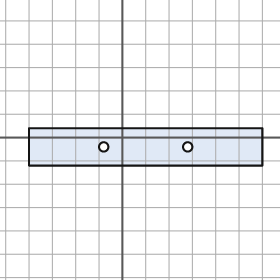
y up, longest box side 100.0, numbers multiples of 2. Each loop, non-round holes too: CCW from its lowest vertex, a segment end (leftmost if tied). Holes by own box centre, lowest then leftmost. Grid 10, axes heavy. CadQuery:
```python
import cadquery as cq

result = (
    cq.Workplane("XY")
    .moveTo(-40.0, -12.0)
    .lineTo(60.0, -12.0)
    .lineTo(60.0, 4.0)
    .lineTo(-40.0, 4.0)
    .close()
    .moveTo(-8.0, -4.0)
    .circle(2.0)
    .moveTo(28.0, -4.0)
    .circle(2.0)
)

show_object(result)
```